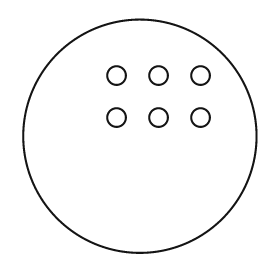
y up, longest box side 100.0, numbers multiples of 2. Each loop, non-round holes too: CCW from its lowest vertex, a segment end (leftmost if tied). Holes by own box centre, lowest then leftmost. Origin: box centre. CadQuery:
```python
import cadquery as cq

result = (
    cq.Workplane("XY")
    .moveTo(0.0, 0.0)
    .circle(50.0)
    .moveTo(-10.0, 8.0)
    .circle(4.0)
    .moveTo(8.0, 8.0)
    .circle(4.0)
    .moveTo(26.0, 8.0)
    .circle(4.0)
    .moveTo(-10.0, 26.0)
    .circle(4.0)
    .moveTo(8.0, 26.0)
    .circle(4.0)
    .moveTo(26.0, 26.0)
    .circle(4.0)
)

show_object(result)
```